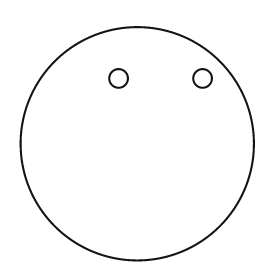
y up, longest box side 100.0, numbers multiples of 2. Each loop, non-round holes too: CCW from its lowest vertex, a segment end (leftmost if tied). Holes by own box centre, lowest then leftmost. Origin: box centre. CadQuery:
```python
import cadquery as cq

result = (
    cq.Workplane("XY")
    .moveTo(0.0, 0.0)
    .circle(50.0)
    .moveTo(-8.0, 28.0)
    .circle(4.0)
    .moveTo(28.0, 28.0)
    .circle(4.0)
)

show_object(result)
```